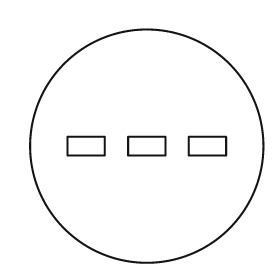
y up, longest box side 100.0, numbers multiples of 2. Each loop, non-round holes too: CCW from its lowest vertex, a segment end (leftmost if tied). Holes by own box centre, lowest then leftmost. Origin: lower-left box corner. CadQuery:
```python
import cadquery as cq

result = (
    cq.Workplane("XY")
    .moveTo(50.0, 50.0)
    .circle(50.0)
    .moveTo(16.0, 46.0)
    .lineTo(32.0, 46.0)
    .lineTo(32.0, 54.0)
    .lineTo(16.0, 54.0)
    .close()
    .moveTo(42.0, 46.0)
    .lineTo(58.0, 46.0)
    .lineTo(58.0, 54.0)
    .lineTo(42.0, 54.0)
    .close()
    .moveTo(68.0, 46.0)
    .lineTo(84.0, 46.0)
    .lineTo(84.0, 54.0)
    .lineTo(68.0, 54.0)
    .close()
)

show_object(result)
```